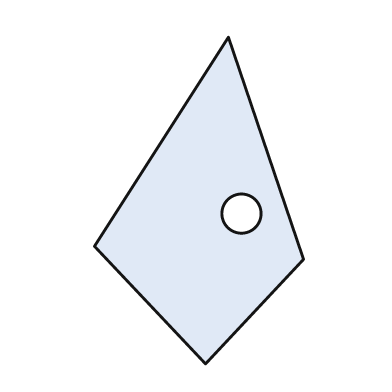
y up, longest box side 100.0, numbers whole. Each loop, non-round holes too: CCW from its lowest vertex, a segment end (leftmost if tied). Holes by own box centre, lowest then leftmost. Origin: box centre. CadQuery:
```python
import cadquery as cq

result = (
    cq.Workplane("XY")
    .moveTo(2.0, -50.0)
    .lineTo(32.0, -18.0)
    .lineTo(9.0, 50.0)
    .lineTo(-32.0, -14.0)
    .close()
    .moveTo(13.0, -4.0)
    .circle(6.0)
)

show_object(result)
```